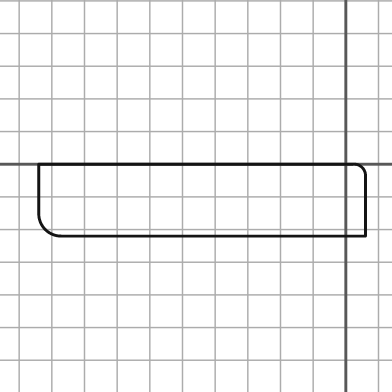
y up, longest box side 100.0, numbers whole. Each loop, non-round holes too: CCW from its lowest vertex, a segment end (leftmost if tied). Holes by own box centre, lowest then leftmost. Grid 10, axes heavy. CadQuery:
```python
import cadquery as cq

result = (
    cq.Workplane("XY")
    .moveTo(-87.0, -22.0)
    .lineTo(6.0, -22.0)
    .lineTo(6.0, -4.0)
    .threePointArc((5.0, -1.0), (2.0, 0.0))
    .lineTo(-94.0, 0.0)
    .lineTo(-94.0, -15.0)
    .threePointArc((-92.0, -20.0), (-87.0, -22.0))
    .close()
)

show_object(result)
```